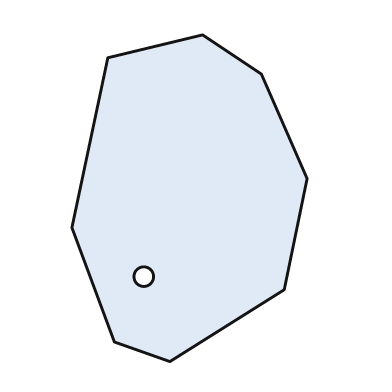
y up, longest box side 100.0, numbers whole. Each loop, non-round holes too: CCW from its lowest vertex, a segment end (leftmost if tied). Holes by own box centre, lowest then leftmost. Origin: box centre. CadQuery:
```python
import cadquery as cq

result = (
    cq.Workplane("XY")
    .moveTo(-6.0, -50.0)
    .lineTo(29.0, -28.0)
    .lineTo(36.0, 6.0)
    .lineTo(22.0, 38.0)
    .lineTo(4.0, 50.0)
    .lineTo(-25.0, 43.0)
    .lineTo(-36.0, -9.0)
    .lineTo(-23.0, -44.0)
    .close()
    .moveTo(-14.0, -24.0)
    .circle(3.0)
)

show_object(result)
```